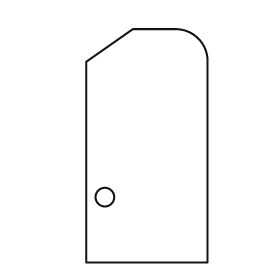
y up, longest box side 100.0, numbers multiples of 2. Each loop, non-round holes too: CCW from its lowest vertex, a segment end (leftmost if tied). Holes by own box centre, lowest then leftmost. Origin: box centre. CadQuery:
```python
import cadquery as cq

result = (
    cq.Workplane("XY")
    .moveTo(-26.0, -50.0)
    .lineTo(26.0, -50.0)
    .lineTo(26.0, 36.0)
    .threePointArc((22.0, 46.0), (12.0, 50.0))
    .lineTo(-6.0, 50.0)
    .lineTo(-26.0, 36.0)
    .close()
    .moveTo(-18.0, -22.0)
    .circle(4.0)
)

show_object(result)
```